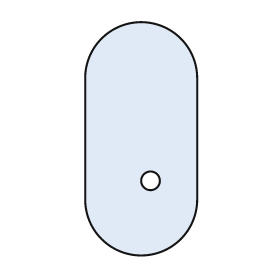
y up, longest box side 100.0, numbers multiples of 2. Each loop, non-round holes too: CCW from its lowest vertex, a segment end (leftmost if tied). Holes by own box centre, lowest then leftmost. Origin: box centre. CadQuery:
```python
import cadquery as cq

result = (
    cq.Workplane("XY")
    .moveTo(-24.0, -26.0)
    .threePointArc((0.0, -50.0), (24.0, -26.0))
    .lineTo(24.0, 26.0)
    .threePointArc((0.0, 50.0), (-24.0, 26.0))
    .close()
    .moveTo(4.0, -18.0)
    .circle(4.0)
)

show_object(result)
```